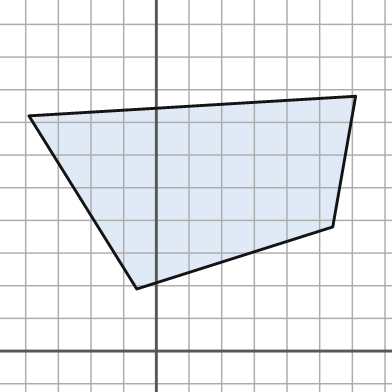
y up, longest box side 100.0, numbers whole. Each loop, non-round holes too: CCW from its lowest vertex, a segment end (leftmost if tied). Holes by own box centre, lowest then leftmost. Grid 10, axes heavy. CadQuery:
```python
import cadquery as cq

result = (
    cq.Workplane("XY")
    .moveTo(-6.0, 19.0)
    .lineTo(54.0, 38.0)
    .lineTo(61.0, 78.0)
    .lineTo(-39.0, 72.0)
    .close()
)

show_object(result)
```